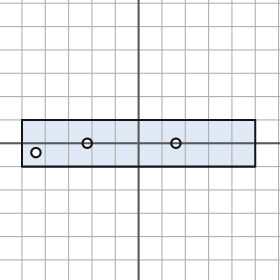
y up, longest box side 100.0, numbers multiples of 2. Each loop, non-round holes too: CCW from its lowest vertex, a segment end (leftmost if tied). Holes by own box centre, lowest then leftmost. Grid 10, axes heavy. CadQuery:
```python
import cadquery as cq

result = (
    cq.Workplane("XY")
    .moveTo(-50.0, -10.0)
    .lineTo(50.0, -10.0)
    .lineTo(50.0, 10.0)
    .lineTo(-50.0, 10.0)
    .close()
    .moveTo(-44.0, -4.0)
    .circle(2.0)
    .moveTo(-22.0, 0.0)
    .circle(2.0)
    .moveTo(16.0, 0.0)
    .circle(2.0)
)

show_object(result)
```